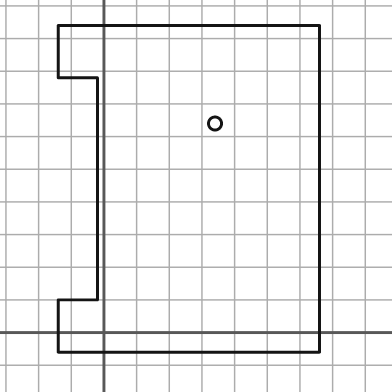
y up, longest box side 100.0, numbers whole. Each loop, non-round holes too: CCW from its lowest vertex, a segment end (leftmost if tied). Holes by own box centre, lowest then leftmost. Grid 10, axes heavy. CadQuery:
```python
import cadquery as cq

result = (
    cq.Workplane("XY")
    .moveTo(-14.0, -6.0)
    .lineTo(66.0, -6.0)
    .lineTo(66.0, 94.0)
    .lineTo(-14.0, 94.0)
    .lineTo(-14.0, 78.0)
    .lineTo(-2.0, 78.0)
    .lineTo(-2.0, 10.0)
    .lineTo(-14.0, 10.0)
    .close()
    .moveTo(34.0, 64.0)
    .circle(2.0)
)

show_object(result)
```